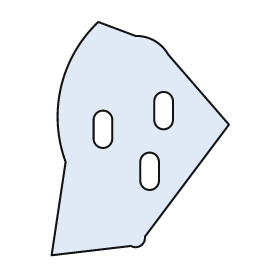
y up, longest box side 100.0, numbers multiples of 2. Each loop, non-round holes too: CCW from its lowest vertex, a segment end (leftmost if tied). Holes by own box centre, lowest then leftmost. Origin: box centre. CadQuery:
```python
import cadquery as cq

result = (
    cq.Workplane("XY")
    .moveTo(-38.0, -50.0)
    .lineTo(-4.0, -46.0)
    .threePointArc((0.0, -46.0), (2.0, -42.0))
    .lineTo(38.0, 6.0)
    .lineTo(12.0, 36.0)
    .threePointArc((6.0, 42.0), (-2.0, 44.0))
    .lineTo(-18.0, 50.0)
    .threePointArc((-34.0, 22.0), (-32.0, -10.0))
    .close()
    .moveTo(0.0, -18.0)
    .threePointArc((4.0, -22.0), (8.0, -18.0))
    .lineTo(8.0, -10.0)
    .threePointArc((4.0, -6.0), (0.0, -10.0))
    .close()
    .moveTo(-20.0, 0.0)
    .threePointArc((-16.0, -4.0), (-12.0, 0.0))
    .lineTo(-12.0, 8.0)
    .threePointArc((-16.0, 12.0), (-20.0, 8.0))
    .close()
    .moveTo(6.0, 8.0)
    .threePointArc((10.0, 4.0), (14.0, 8.0))
    .lineTo(14.0, 16.0)
    .threePointArc((10.0, 20.0), (6.0, 16.0))
    .close()
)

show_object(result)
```